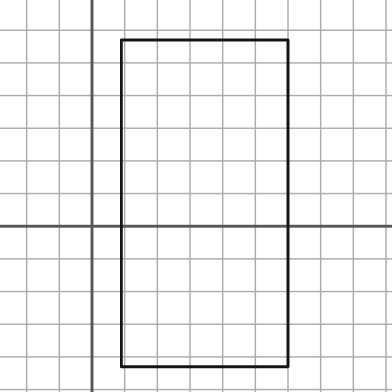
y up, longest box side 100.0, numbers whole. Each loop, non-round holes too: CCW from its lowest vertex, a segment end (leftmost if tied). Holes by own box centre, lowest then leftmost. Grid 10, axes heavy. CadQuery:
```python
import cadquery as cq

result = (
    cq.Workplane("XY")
    .moveTo(9.0, -43.0)
    .lineTo(60.0, -43.0)
    .lineTo(60.0, 57.0)
    .lineTo(9.0, 57.0)
    .close()
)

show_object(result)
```